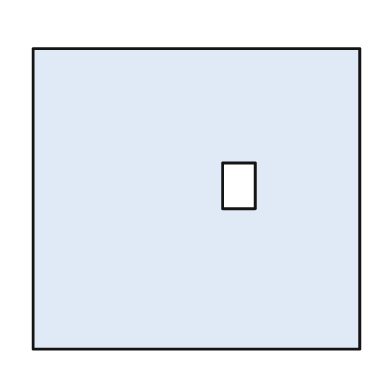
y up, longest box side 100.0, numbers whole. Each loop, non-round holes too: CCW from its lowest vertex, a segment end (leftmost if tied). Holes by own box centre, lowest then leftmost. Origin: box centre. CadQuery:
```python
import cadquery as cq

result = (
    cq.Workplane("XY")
    .moveTo(-50.0, -46.0)
    .lineTo(50.0, -46.0)
    .lineTo(50.0, 46.0)
    .lineTo(-50.0, 46.0)
    .close()
    .moveTo(8.0, -3.0)
    .lineTo(18.0, -3.0)
    .lineTo(18.0, 11.0)
    .lineTo(8.0, 11.0)
    .close()
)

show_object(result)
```